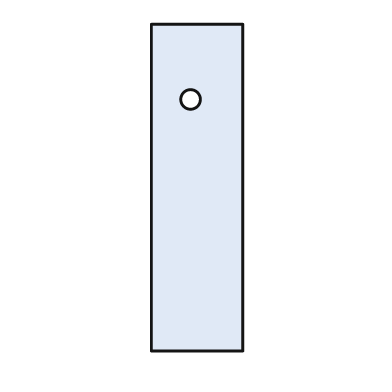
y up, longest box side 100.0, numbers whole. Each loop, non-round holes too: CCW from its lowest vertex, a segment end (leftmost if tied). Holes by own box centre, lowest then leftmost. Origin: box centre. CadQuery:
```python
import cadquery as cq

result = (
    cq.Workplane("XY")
    .moveTo(-14.0, -50.0)
    .lineTo(14.0, -50.0)
    .lineTo(14.0, 50.0)
    .lineTo(-14.0, 50.0)
    .close()
    .moveTo(-2.0, 27.0)
    .circle(3.0)
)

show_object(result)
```